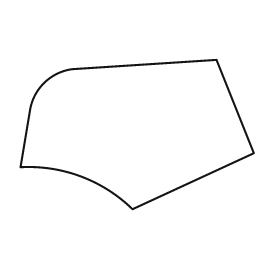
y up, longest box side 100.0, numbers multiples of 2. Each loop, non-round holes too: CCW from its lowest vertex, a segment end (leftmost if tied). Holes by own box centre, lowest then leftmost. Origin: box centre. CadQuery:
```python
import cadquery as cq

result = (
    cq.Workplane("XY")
    .moveTo(-2.0, -32.0)
    .lineTo(50.0, -8.0)
    .lineTo(34.0, 32.0)
    .lineTo(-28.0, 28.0)
    .threePointArc((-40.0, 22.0), (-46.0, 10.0))
    .lineTo(-50.0, -14.0)
    .threePointArc((-24.0, -18.0), (-2.0, -32.0))
    .close()
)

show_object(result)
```